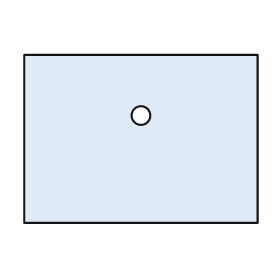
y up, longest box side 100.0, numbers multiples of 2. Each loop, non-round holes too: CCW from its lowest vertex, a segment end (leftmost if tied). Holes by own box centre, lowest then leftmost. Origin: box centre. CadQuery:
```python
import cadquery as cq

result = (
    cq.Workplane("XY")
    .moveTo(-50.0, -36.0)
    .lineTo(50.0, -36.0)
    .lineTo(50.0, 36.0)
    .lineTo(-50.0, 36.0)
    .close()
    .moveTo(0.0, 10.0)
    .circle(4.0)
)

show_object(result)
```